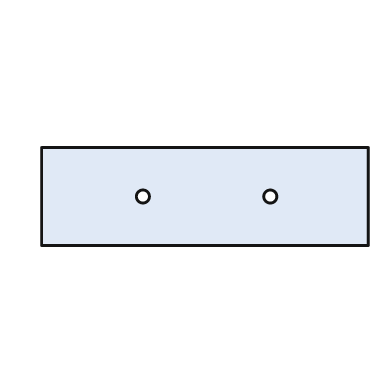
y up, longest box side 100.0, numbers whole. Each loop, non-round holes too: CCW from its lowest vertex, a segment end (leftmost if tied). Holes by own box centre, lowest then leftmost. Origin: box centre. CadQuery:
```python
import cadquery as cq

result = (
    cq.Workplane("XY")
    .moveTo(-50.0, -15.0)
    .lineTo(50.0, -15.0)
    .lineTo(50.0, 15.0)
    .lineTo(-50.0, 15.0)
    .close()
    .moveTo(-19.0, 0.0)
    .circle(2.0)
    .moveTo(20.0, 0.0)
    .circle(2.0)
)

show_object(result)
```